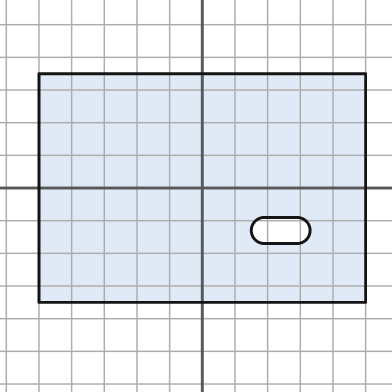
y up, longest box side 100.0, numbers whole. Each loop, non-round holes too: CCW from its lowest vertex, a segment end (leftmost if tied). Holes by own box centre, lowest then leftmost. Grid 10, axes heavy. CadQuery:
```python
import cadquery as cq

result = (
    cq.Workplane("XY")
    .moveTo(-50.0, -35.0)
    .lineTo(50.0, -35.0)
    .lineTo(50.0, 35.0)
    .lineTo(-50.0, 35.0)
    .close()
    .moveTo(19.0, -17.0)
    .lineTo(29.0, -17.0)
    .threePointArc((33.0, -13.0), (29.0, -9.0))
    .lineTo(19.0, -9.0)
    .threePointArc((15.0, -13.0), (19.0, -17.0))
    .close()
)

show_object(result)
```